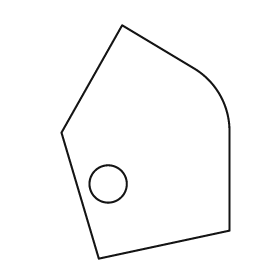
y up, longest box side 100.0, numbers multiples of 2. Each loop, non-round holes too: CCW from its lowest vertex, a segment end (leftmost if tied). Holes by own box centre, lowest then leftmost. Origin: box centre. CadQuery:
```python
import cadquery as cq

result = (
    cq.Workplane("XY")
    .moveTo(-20.0, -50.0)
    .lineTo(36.0, -38.0)
    .lineTo(36.0, 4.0)
    .threePointArc((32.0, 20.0), (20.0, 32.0))
    .lineTo(-10.0, 50.0)
    .lineTo(-36.0, 4.0)
    .close()
    .moveTo(-16.0, -18.0)
    .circle(8.0)
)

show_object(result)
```